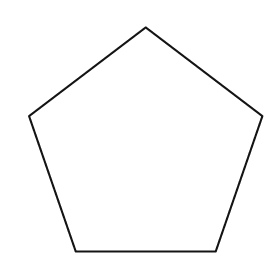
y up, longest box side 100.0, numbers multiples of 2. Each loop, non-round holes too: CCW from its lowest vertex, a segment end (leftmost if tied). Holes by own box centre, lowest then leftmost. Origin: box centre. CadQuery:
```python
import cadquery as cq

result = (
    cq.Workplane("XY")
    .moveTo(-30.0, -48.0)
    .lineTo(30.0, -48.0)
    .lineTo(50.0, 10.0)
    .lineTo(0.0, 48.0)
    .lineTo(-50.0, 10.0)
    .close()
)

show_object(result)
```